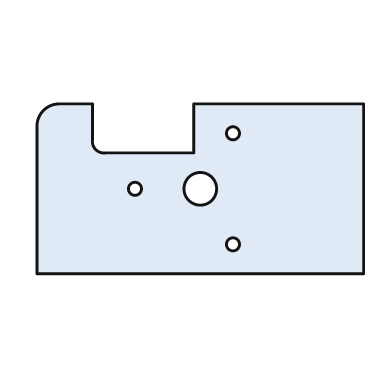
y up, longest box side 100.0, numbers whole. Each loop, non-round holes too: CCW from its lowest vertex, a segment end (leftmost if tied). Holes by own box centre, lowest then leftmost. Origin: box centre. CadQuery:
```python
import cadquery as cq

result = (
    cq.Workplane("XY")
    .moveTo(-50.0, -26.0)
    .lineTo(50.0, -26.0)
    .lineTo(50.0, 26.0)
    .lineTo(-2.0, 26.0)
    .lineTo(-2.0, 11.0)
    .lineTo(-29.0, 11.0)
    .threePointArc((-32.0, 12.0), (-33.0, 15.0))
    .lineTo(-33.0, 26.0)
    .lineTo(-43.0, 26.0)
    .threePointArc((-48.0, 24.0), (-50.0, 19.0))
    .close()
    .moveTo(10.0, -17.0)
    .circle(2.0)
    .moveTo(-20.0, 0.0)
    .circle(2.0)
    .moveTo(0.0, 0.0)
    .circle(5.0)
    .moveTo(10.0, 17.0)
    .circle(2.0)
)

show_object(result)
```